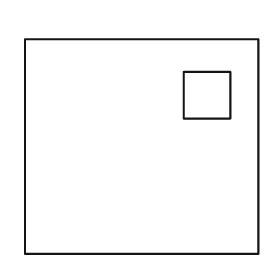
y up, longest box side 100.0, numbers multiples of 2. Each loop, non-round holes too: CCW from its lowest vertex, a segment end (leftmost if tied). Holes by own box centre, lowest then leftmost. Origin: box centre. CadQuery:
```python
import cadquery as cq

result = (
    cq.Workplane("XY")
    .moveTo(-50.0, -46.0)
    .lineTo(50.0, -46.0)
    .lineTo(50.0, 46.0)
    .lineTo(-50.0, 46.0)
    .close()
    .moveTo(18.0, 12.0)
    .lineTo(38.0, 12.0)
    .lineTo(38.0, 32.0)
    .lineTo(18.0, 32.0)
    .close()
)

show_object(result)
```